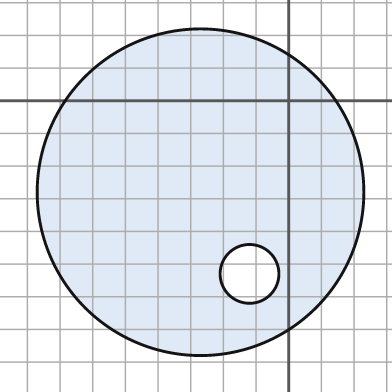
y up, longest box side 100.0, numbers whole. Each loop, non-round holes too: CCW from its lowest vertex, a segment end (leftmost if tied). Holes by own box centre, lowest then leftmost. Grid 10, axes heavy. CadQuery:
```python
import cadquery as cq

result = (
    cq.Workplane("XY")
    .moveTo(-27.0, -28.0)
    .circle(50.0)
    .moveTo(-12.0, -53.0)
    .circle(9.0)
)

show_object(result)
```